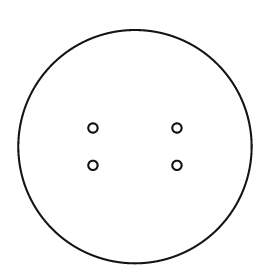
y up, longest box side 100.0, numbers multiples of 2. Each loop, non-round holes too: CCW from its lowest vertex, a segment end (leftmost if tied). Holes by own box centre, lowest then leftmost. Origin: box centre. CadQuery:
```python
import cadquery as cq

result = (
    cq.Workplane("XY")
    .moveTo(0.0, 0.0)
    .circle(50.0)
    .moveTo(-18.0, -8.0)
    .circle(2.0)
    .moveTo(18.0, -8.0)
    .circle(2.0)
    .moveTo(-18.0, 8.0)
    .circle(2.0)
    .moveTo(18.0, 8.0)
    .circle(2.0)
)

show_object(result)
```